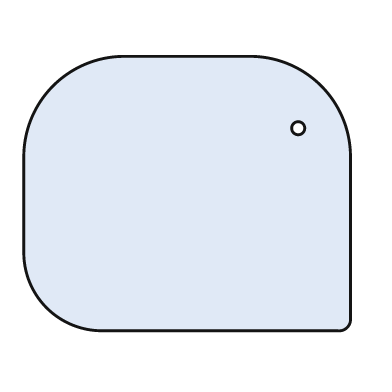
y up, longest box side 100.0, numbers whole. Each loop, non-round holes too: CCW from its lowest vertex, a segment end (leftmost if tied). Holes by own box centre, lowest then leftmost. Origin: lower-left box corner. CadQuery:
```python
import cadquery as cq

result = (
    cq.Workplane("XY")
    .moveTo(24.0, 0.0)
    .lineTo(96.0, 0.0)
    .threePointArc((99.0, 1.0), (100.0, 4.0))
    .lineTo(100.0, 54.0)
    .threePointArc((91.0, 75.0), (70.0, 84.0))
    .lineTo(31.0, 84.0)
    .threePointArc((9.0, 75.0), (0.0, 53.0))
    .lineTo(0.0, 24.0)
    .threePointArc((7.0, 7.0), (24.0, 0.0))
    .close()
    .moveTo(84.0, 62.0)
    .circle(2.0)
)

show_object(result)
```